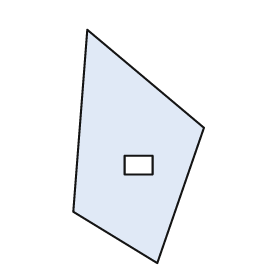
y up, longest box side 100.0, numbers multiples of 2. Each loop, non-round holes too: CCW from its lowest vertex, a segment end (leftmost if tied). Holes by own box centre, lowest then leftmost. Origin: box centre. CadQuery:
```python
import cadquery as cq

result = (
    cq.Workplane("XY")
    .moveTo(8.0, -50.0)
    .lineTo(28.0, 8.0)
    .lineTo(-22.0, 50.0)
    .lineTo(-28.0, -28.0)
    .close()
    .moveTo(-6.0, -12.0)
    .lineTo(6.0, -12.0)
    .lineTo(6.0, -4.0)
    .lineTo(-6.0, -4.0)
    .close()
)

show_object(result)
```